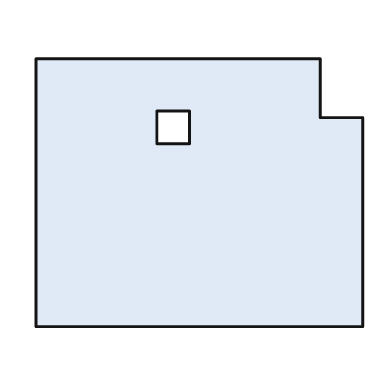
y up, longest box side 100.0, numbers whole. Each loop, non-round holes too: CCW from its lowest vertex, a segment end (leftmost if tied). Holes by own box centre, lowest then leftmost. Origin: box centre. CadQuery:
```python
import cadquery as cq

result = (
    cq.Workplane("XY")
    .moveTo(-50.0, -41.0)
    .lineTo(50.0, -41.0)
    .lineTo(50.0, 23.0)
    .lineTo(37.0, 23.0)
    .lineTo(37.0, 41.0)
    .lineTo(-50.0, 41.0)
    .close()
    .moveTo(-13.0, 15.0)
    .lineTo(-3.0, 15.0)
    .lineTo(-3.0, 25.0)
    .lineTo(-13.0, 25.0)
    .close()
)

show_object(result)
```